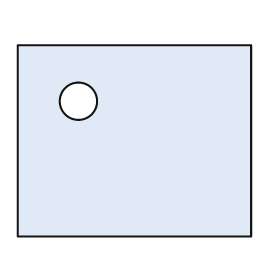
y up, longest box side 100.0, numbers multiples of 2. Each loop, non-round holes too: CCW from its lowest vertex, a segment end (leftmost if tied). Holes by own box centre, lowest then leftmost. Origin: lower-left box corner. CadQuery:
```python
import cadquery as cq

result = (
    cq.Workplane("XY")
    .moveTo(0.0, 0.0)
    .lineTo(100.0, 0.0)
    .lineTo(100.0, 82.0)
    .lineTo(0.0, 82.0)
    .close()
    .moveTo(26.0, 58.0)
    .circle(8.0)
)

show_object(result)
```